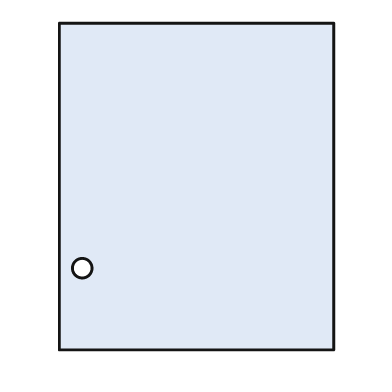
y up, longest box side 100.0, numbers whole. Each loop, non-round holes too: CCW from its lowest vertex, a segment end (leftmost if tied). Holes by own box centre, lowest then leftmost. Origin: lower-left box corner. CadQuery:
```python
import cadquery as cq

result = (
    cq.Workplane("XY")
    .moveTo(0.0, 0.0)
    .lineTo(84.0, 0.0)
    .lineTo(84.0, 100.0)
    .lineTo(0.0, 100.0)
    .close()
    .moveTo(7.0, 25.0)
    .circle(3.0)
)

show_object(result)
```